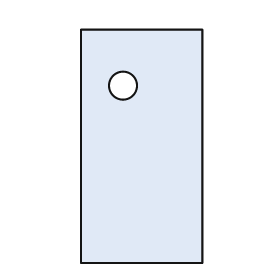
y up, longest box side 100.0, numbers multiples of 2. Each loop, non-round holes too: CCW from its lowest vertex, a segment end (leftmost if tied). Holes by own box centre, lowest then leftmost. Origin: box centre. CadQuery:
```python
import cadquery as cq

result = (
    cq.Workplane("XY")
    .moveTo(-26.0, -50.0)
    .lineTo(26.0, -50.0)
    .lineTo(26.0, 50.0)
    .lineTo(-26.0, 50.0)
    .close()
    .moveTo(-8.0, 26.0)
    .circle(6.0)
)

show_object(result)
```